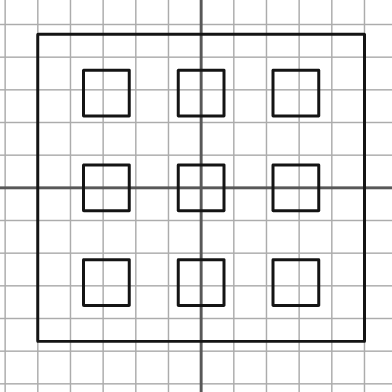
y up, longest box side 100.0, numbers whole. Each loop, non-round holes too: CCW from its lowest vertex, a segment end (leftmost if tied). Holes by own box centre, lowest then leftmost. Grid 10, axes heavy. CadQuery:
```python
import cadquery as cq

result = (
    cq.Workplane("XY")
    .moveTo(-50.0, -47.0)
    .lineTo(50.0, -47.0)
    .lineTo(50.0, 47.0)
    .lineTo(-50.0, 47.0)
    .close()
    .moveTo(-36.0, -36.0)
    .lineTo(-22.0, -36.0)
    .lineTo(-22.0, -22.0)
    .lineTo(-36.0, -22.0)
    .close()
    .moveTo(-7.0, -36.0)
    .lineTo(7.0, -36.0)
    .lineTo(7.0, -22.0)
    .lineTo(-7.0, -22.0)
    .close()
    .moveTo(22.0, -36.0)
    .lineTo(36.0, -36.0)
    .lineTo(36.0, -22.0)
    .lineTo(22.0, -22.0)
    .close()
    .moveTo(-36.0, -7.0)
    .lineTo(-22.0, -7.0)
    .lineTo(-22.0, 7.0)
    .lineTo(-36.0, 7.0)
    .close()
    .moveTo(-7.0, -7.0)
    .lineTo(7.0, -7.0)
    .lineTo(7.0, 7.0)
    .lineTo(-7.0, 7.0)
    .close()
    .moveTo(22.0, -7.0)
    .lineTo(36.0, -7.0)
    .lineTo(36.0, 7.0)
    .lineTo(22.0, 7.0)
    .close()
    .moveTo(-36.0, 22.0)
    .lineTo(-22.0, 22.0)
    .lineTo(-22.0, 36.0)
    .lineTo(-36.0, 36.0)
    .close()
    .moveTo(-7.0, 22.0)
    .lineTo(7.0, 22.0)
    .lineTo(7.0, 36.0)
    .lineTo(-7.0, 36.0)
    .close()
    .moveTo(22.0, 22.0)
    .lineTo(36.0, 22.0)
    .lineTo(36.0, 36.0)
    .lineTo(22.0, 36.0)
    .close()
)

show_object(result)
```